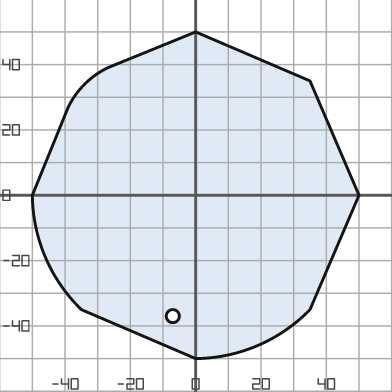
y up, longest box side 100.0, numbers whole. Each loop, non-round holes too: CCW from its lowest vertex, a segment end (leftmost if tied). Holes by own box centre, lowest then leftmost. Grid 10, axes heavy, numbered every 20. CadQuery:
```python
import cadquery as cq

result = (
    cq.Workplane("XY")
    .moveTo(0.0, -50.0)
    .threePointArc((19.0, -46.0), (35.0, -35.0))
    .lineTo(50.0, 0.0)
    .lineTo(35.0, 35.0)
    .lineTo(0.0, 50.0)
    .lineTo(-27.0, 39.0)
    .threePointArc((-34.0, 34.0), (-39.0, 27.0))
    .lineTo(-50.0, 0.0)
    .threePointArc((-46.0, -19.0), (-35.0, -35.0))
    .close()
    .moveTo(-7.0, -37.0)
    .circle(2.0)
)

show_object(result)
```